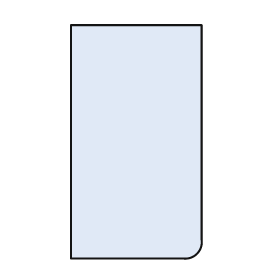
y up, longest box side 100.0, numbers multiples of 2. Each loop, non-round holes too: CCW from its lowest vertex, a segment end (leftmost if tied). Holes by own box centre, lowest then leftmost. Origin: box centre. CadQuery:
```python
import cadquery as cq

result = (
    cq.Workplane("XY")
    .moveTo(-28.0, -50.0)
    .lineTo(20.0, -50.0)
    .threePointArc((26.0, -48.0), (28.0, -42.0))
    .lineTo(28.0, 50.0)
    .lineTo(-28.0, 50.0)
    .close()
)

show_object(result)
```